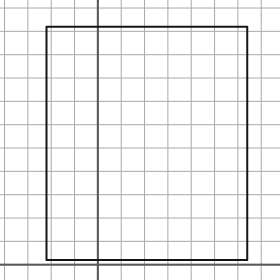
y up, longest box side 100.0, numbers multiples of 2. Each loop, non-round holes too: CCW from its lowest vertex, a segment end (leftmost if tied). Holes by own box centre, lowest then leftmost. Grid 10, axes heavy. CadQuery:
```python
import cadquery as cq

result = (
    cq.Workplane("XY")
    .moveTo(-22.0, 2.0)
    .lineTo(64.0, 2.0)
    .lineTo(64.0, 102.0)
    .lineTo(-22.0, 102.0)
    .close()
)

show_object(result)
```